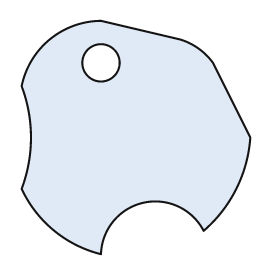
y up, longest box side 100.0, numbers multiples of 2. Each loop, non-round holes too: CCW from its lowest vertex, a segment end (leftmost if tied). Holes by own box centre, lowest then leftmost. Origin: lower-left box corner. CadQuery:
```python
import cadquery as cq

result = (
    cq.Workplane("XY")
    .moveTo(34.0, 0.0)
    .threePointArc((52.0, 22.0), (78.0, 10.0))
    .threePointArc((92.0, 28.0), (98.0, 50.0))
    .lineTo(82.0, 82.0)
    .threePointArc((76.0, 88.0), (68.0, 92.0))
    .lineTo(34.0, 100.0)
    .threePointArc((12.0, 92.0), (0.0, 72.0))
    .threePointArc((4.0, 50.0), (0.0, 28.0))
    .threePointArc((14.0, 10.0), (34.0, 0.0))
    .close()
    .moveTo(34.0, 82.0)
    .circle(8.0)
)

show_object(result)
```